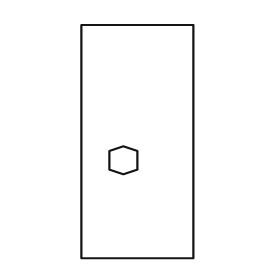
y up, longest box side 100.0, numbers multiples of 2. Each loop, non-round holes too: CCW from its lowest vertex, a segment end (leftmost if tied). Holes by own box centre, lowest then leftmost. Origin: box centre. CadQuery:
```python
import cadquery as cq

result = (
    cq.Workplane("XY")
    .moveTo(-24.0, -50.0)
    .lineTo(24.0, -50.0)
    .lineTo(24.0, 50.0)
    .lineTo(-24.0, 50.0)
    .close()
    .moveTo(-6.0, -14.0)
    .lineTo(0.0, -12.0)
    .lineTo(0.0, -4.0)
    .lineTo(-6.0, -2.0)
    .lineTo(-12.0, -4.0)
    .lineTo(-12.0, -12.0)
    .close()
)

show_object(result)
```